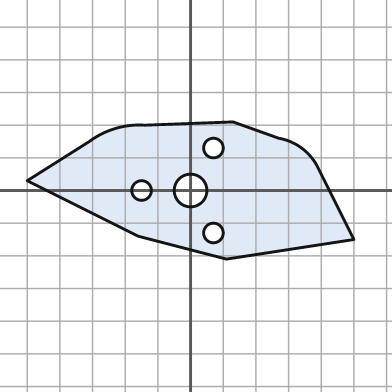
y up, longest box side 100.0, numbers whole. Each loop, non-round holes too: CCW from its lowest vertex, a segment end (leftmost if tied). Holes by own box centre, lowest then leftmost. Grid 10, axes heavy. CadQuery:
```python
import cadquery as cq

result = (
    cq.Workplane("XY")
    .moveTo(11.0, -21.0)
    .lineTo(50.0, -15.0)
    .lineTo(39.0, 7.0)
    .threePointArc((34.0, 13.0), (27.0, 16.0))
    .lineTo(13.0, 21.0)
    .lineTo(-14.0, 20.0)
    .threePointArc((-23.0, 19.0), (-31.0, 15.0))
    .lineTo(-50.0, 3.0)
    .lineTo(-16.0, -14.0)
    .close()
    .moveTo(7.0, -13.0)
    .circle(3.0)
    .moveTo(-15.0, 0.0)
    .circle(3.0)
    .moveTo(0.0, 0.0)
    .circle(5.0)
    .moveTo(7.0, 13.0)
    .circle(3.0)
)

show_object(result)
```